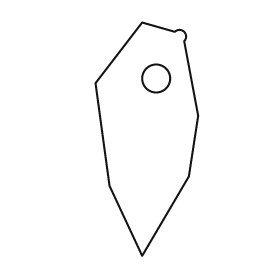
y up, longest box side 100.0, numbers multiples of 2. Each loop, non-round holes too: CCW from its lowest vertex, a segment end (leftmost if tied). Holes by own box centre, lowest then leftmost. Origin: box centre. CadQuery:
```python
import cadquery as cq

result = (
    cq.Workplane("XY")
    .moveTo(-2.0, -50.0)
    .lineTo(18.0, -16.0)
    .lineTo(22.0, 10.0)
    .lineTo(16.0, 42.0)
    .threePointArc((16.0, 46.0), (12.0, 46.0))
    .lineTo(-2.0, 50.0)
    .lineTo(-22.0, 24.0)
    .lineTo(-16.0, -20.0)
    .close()
    .moveTo(4.0, 26.0)
    .circle(6.0)
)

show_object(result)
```